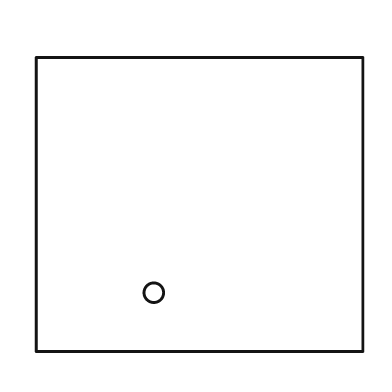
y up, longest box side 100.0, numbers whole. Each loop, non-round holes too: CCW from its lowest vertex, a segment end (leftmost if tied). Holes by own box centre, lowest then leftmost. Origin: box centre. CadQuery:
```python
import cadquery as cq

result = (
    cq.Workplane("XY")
    .moveTo(-50.0, -45.0)
    .lineTo(50.0, -45.0)
    .lineTo(50.0, 45.0)
    .lineTo(-50.0, 45.0)
    .close()
    .moveTo(-14.0, -27.0)
    .circle(3.0)
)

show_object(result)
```